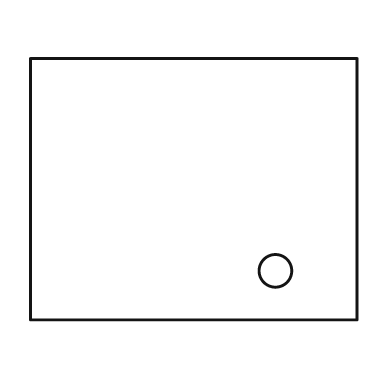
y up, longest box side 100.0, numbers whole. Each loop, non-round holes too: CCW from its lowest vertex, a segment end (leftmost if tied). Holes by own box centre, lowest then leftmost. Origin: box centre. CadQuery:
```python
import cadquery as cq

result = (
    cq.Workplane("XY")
    .moveTo(-50.0, -40.0)
    .lineTo(50.0, -40.0)
    .lineTo(50.0, 40.0)
    .lineTo(-50.0, 40.0)
    .close()
    .moveTo(25.0, -25.0)
    .circle(5.0)
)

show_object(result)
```